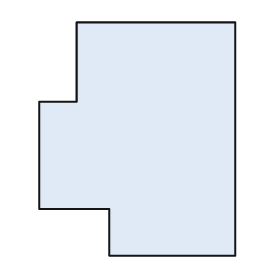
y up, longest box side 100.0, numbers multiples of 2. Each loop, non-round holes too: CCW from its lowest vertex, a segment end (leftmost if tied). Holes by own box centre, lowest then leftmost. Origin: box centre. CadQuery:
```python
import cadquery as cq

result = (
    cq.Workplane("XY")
    .moveTo(-12.0, -50.0)
    .lineTo(42.0, -50.0)
    .lineTo(42.0, 50.0)
    .lineTo(-26.0, 50.0)
    .lineTo(-26.0, 16.0)
    .lineTo(-42.0, 16.0)
    .lineTo(-42.0, -30.0)
    .lineTo(-12.0, -30.0)
    .close()
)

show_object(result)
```